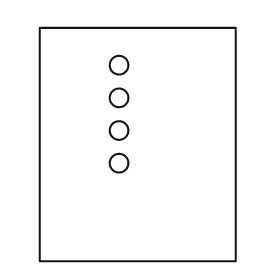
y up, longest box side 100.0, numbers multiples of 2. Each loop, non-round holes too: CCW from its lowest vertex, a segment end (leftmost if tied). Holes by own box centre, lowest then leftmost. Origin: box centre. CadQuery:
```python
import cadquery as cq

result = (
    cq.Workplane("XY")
    .moveTo(-42.0, -50.0)
    .lineTo(42.0, -50.0)
    .lineTo(42.0, 50.0)
    .lineTo(-42.0, 50.0)
    .close()
    .moveTo(-8.0, -8.0)
    .circle(4.0)
    .moveTo(-8.0, 6.0)
    .circle(4.0)
    .moveTo(-8.0, 20.0)
    .circle(4.0)
    .moveTo(-8.0, 34.0)
    .circle(4.0)
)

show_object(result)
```